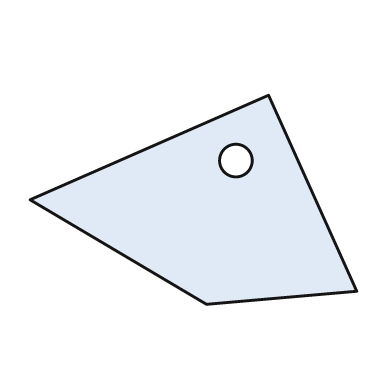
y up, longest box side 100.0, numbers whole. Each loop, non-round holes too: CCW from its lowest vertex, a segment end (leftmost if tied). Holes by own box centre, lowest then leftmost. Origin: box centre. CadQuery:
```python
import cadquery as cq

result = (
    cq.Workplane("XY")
    .moveTo(4.0, -32.0)
    .lineTo(50.0, -28.0)
    .lineTo(23.0, 32.0)
    .lineTo(-50.0, 0.0)
    .close()
    .moveTo(13.0, 12.0)
    .circle(5.0)
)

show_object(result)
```